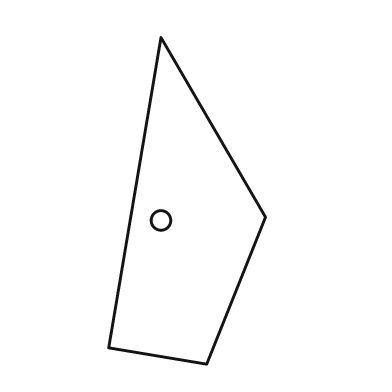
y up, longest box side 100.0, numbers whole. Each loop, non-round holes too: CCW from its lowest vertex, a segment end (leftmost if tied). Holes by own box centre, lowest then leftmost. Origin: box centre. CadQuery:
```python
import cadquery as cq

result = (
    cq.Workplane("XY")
    .moveTo(6.0, -50.0)
    .lineTo(24.0, -5.0)
    .lineTo(-8.0, 50.0)
    .lineTo(-24.0, -45.0)
    .close()
    .moveTo(-8.0, -6.0)
    .circle(3.0)
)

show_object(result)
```